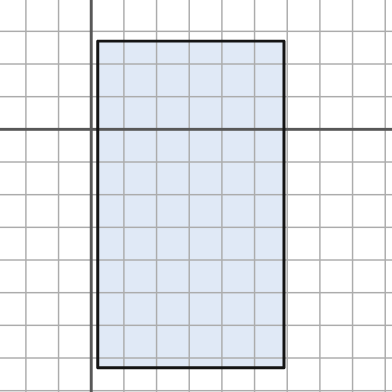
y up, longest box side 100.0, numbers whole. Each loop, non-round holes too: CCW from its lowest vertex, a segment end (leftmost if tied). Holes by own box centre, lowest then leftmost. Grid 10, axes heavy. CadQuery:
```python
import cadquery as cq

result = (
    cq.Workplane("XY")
    .moveTo(2.0, -73.0)
    .lineTo(59.0, -73.0)
    .lineTo(59.0, 27.0)
    .lineTo(2.0, 27.0)
    .close()
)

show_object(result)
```